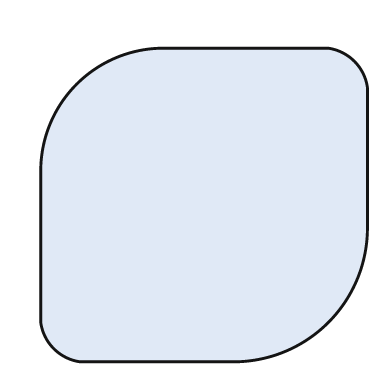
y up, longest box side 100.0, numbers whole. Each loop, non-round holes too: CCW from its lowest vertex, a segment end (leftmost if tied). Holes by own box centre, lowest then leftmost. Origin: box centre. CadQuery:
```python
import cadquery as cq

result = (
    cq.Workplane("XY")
    .moveTo(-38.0, -48.0)
    .lineTo(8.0, -48.0)
    .threePointArc((38.0, -36.0), (50.0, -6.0))
    .lineTo(50.0, 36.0)
    .threePointArc((46.0, 44.0), (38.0, 48.0))
    .lineTo(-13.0, 48.0)
    .threePointArc((-39.0, 37.0), (-50.0, 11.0))
    .lineTo(-50.0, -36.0)
    .threePointArc((-46.0, -44.0), (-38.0, -48.0))
    .close()
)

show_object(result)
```